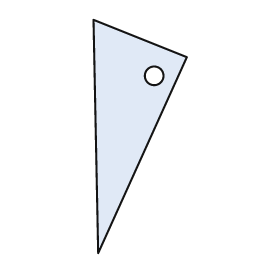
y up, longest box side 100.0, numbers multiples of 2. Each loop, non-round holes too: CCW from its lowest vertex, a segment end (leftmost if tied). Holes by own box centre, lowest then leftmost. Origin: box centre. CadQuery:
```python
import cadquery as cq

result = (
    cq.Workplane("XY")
    .moveTo(-18.0, -50.0)
    .lineTo(20.0, 34.0)
    .lineTo(-20.0, 50.0)
    .close()
    .moveTo(6.0, 26.0)
    .circle(4.0)
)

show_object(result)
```